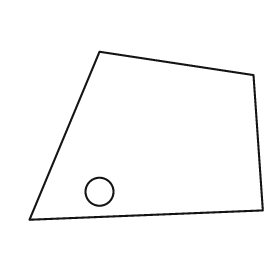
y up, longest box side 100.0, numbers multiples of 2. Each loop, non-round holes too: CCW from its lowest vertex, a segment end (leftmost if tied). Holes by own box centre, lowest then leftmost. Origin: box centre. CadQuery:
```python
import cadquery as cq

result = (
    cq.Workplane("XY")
    .moveTo(-50.0, -36.0)
    .lineTo(50.0, -32.0)
    .lineTo(46.0, 26.0)
    .lineTo(-20.0, 36.0)
    .close()
    .moveTo(-20.0, -24.0)
    .circle(6.0)
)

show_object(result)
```